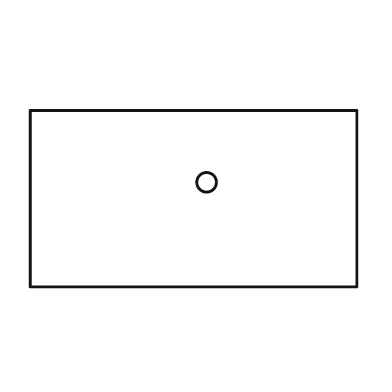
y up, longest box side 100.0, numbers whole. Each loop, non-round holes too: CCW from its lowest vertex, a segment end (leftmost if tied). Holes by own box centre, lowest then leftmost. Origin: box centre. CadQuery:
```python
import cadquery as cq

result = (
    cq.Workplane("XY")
    .moveTo(-50.0, -27.0)
    .lineTo(50.0, -27.0)
    .lineTo(50.0, 27.0)
    .lineTo(-50.0, 27.0)
    .close()
    .moveTo(4.0, 5.0)
    .circle(3.0)
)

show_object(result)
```